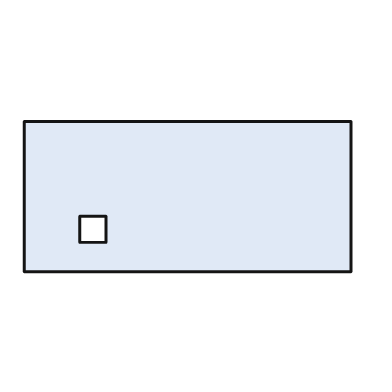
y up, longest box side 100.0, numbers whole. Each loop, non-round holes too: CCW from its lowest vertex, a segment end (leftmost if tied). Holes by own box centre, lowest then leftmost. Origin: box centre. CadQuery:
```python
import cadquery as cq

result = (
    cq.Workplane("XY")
    .moveTo(-50.0, -23.0)
    .lineTo(50.0, -23.0)
    .lineTo(50.0, 23.0)
    .lineTo(-50.0, 23.0)
    .close()
    .moveTo(-33.0, -14.0)
    .lineTo(-25.0, -14.0)
    .lineTo(-25.0, -6.0)
    .lineTo(-33.0, -6.0)
    .close()
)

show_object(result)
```